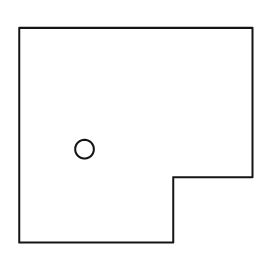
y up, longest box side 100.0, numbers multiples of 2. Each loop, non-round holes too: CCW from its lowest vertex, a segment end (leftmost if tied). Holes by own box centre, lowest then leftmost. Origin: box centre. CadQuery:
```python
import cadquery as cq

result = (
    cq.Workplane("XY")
    .moveTo(-50.0, -46.0)
    .lineTo(16.0, -46.0)
    .lineTo(16.0, -18.0)
    .lineTo(50.0, -18.0)
    .lineTo(50.0, 46.0)
    .lineTo(-50.0, 46.0)
    .close()
    .moveTo(-22.0, -6.0)
    .circle(4.0)
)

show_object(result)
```